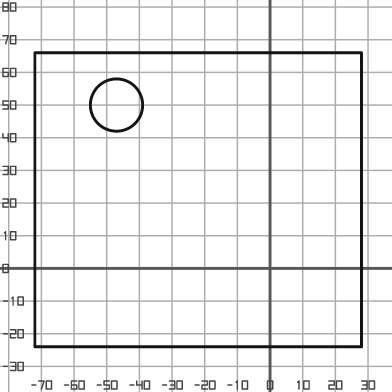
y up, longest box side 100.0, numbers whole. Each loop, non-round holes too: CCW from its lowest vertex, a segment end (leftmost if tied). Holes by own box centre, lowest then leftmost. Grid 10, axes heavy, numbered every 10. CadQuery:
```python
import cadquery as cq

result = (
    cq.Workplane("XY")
    .moveTo(-72.0, -24.0)
    .lineTo(28.0, -24.0)
    .lineTo(28.0, 66.0)
    .lineTo(-72.0, 66.0)
    .close()
    .moveTo(-47.0, 50.0)
    .circle(8.0)
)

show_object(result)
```